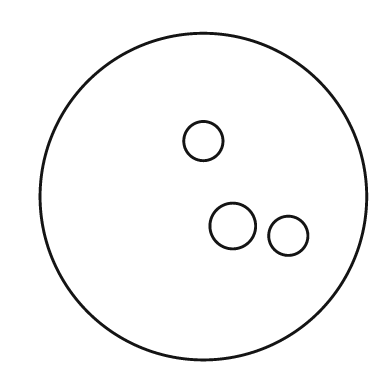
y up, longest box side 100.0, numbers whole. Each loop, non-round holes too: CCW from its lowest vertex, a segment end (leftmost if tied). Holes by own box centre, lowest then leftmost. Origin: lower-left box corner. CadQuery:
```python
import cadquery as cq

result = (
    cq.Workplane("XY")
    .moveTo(50.0, 50.0)
    .circle(50.0)
    .moveTo(76.0, 38.0)
    .circle(6.0)
    .moveTo(59.0, 41.0)
    .circle(7.0)
    .moveTo(50.0, 67.0)
    .circle(6.0)
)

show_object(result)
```